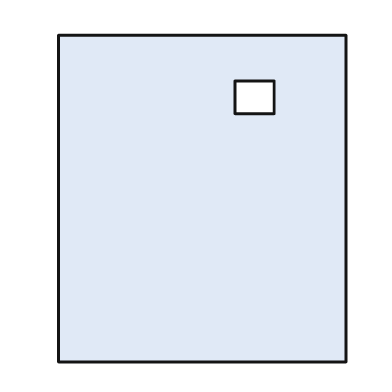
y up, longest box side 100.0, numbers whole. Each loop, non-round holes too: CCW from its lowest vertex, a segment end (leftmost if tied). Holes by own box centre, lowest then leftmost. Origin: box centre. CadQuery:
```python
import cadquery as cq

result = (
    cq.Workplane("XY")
    .moveTo(-44.0, -50.0)
    .lineTo(44.0, -50.0)
    .lineTo(44.0, 50.0)
    .lineTo(-44.0, 50.0)
    .close()
    .moveTo(10.0, 26.0)
    .lineTo(22.0, 26.0)
    .lineTo(22.0, 36.0)
    .lineTo(10.0, 36.0)
    .close()
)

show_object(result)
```